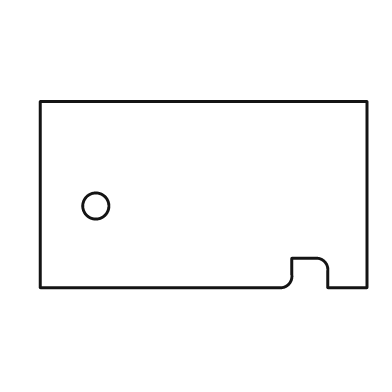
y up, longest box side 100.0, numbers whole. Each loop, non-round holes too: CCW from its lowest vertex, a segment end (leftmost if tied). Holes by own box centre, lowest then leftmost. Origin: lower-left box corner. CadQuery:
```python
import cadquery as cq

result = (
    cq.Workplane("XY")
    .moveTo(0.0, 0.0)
    .lineTo(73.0, 0.0)
    .threePointArc((76.0, 1.0), (77.0, 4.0))
    .lineTo(77.0, 9.0)
    .lineTo(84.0, 9.0)
    .threePointArc((87.0, 8.0), (88.0, 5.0))
    .lineTo(88.0, 0.0)
    .lineTo(100.0, 0.0)
    .lineTo(100.0, 57.0)
    .lineTo(0.0, 57.0)
    .close()
    .moveTo(17.0, 25.0)
    .circle(4.0)
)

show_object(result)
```